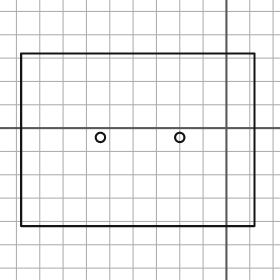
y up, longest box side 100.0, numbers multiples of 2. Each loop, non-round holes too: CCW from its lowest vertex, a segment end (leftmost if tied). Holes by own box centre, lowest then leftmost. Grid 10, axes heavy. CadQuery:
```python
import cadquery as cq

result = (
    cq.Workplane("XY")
    .moveTo(-88.0, -42.0)
    .lineTo(12.0, -42.0)
    .lineTo(12.0, 32.0)
    .lineTo(-88.0, 32.0)
    .close()
    .moveTo(-54.0, -4.0)
    .circle(2.0)
    .moveTo(-20.0, -4.0)
    .circle(2.0)
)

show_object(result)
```